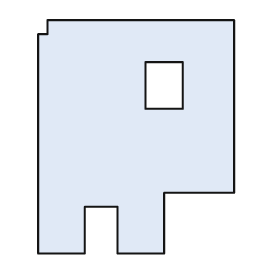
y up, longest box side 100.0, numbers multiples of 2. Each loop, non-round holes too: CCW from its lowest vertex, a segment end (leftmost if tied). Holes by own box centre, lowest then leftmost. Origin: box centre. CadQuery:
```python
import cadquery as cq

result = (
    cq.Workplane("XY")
    .moveTo(-42.0, -50.0)
    .lineTo(-22.0, -50.0)
    .lineTo(-22.0, -30.0)
    .lineTo(-8.0, -30.0)
    .lineTo(-8.0, -50.0)
    .lineTo(12.0, -50.0)
    .lineTo(12.0, -24.0)
    .lineTo(42.0, -24.0)
    .lineTo(42.0, 50.0)
    .lineTo(-38.0, 50.0)
    .lineTo(-38.0, 44.0)
    .lineTo(-42.0, 44.0)
    .close()
    .moveTo(4.0, 12.0)
    .lineTo(20.0, 12.0)
    .lineTo(20.0, 32.0)
    .lineTo(4.0, 32.0)
    .close()
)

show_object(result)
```